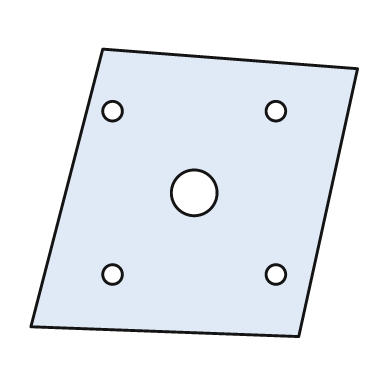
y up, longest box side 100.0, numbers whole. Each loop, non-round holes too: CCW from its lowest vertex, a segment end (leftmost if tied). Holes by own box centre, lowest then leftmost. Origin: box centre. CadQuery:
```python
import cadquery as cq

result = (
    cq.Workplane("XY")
    .moveTo(32.0, -44.0)
    .lineTo(50.0, 38.0)
    .lineTo(-28.0, 44.0)
    .lineTo(-50.0, -41.0)
    .close()
    .moveTo(-25.0, -25.0)
    .circle(3.0)
    .moveTo(25.0, -25.0)
    .circle(3.0)
    .moveTo(0.0, 0.0)
    .circle(7.0)
    .moveTo(-25.0, 25.0)
    .circle(3.0)
    .moveTo(25.0, 25.0)
    .circle(3.0)
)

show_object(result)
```